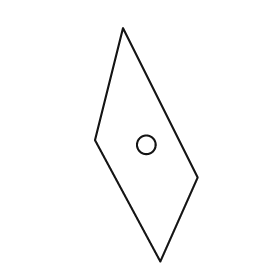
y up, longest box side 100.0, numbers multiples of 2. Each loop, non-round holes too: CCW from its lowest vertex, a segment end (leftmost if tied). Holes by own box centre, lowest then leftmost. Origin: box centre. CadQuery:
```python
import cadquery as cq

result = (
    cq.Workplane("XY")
    .moveTo(6.0, -50.0)
    .lineTo(22.0, -14.0)
    .lineTo(-10.0, 50.0)
    .lineTo(-22.0, 2.0)
    .close()
    .moveTo(0.0, 0.0)
    .circle(4.0)
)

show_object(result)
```